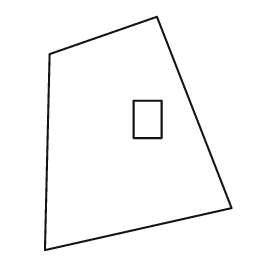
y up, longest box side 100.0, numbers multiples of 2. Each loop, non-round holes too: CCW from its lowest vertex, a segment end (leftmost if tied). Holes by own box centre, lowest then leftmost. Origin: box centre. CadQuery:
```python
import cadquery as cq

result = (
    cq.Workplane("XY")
    .moveTo(-40.0, -50.0)
    .lineTo(40.0, -32.0)
    .lineTo(8.0, 50.0)
    .lineTo(-38.0, 34.0)
    .close()
    .moveTo(-2.0, -2.0)
    .lineTo(10.0, -2.0)
    .lineTo(10.0, 14.0)
    .lineTo(-2.0, 14.0)
    .close()
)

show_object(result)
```